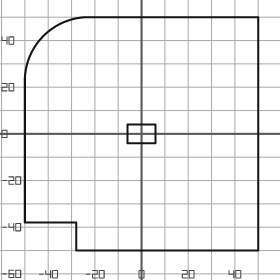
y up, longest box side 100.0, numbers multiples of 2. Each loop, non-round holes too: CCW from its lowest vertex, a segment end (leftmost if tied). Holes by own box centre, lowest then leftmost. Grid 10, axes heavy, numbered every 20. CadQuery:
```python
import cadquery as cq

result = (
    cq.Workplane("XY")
    .moveTo(-28.0, -50.0)
    .lineTo(50.0, -50.0)
    .lineTo(50.0, 50.0)
    .lineTo(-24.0, 50.0)
    .threePointArc((-42.0, 42.0), (-50.0, 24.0))
    .lineTo(-50.0, -38.0)
    .lineTo(-28.0, -38.0)
    .close()
    .moveTo(-6.0, -4.0)
    .lineTo(6.0, -4.0)
    .lineTo(6.0, 4.0)
    .lineTo(-6.0, 4.0)
    .close()
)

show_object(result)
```